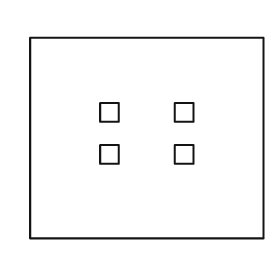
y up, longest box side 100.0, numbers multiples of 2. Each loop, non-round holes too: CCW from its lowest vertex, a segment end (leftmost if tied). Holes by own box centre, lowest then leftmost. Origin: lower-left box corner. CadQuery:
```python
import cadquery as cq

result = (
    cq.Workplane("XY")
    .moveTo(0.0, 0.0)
    .lineTo(100.0, 0.0)
    .lineTo(100.0, 86.0)
    .lineTo(0.0, 86.0)
    .close()
    .moveTo(30.0, 32.0)
    .lineTo(38.0, 32.0)
    .lineTo(38.0, 40.0)
    .lineTo(30.0, 40.0)
    .close()
    .moveTo(62.0, 32.0)
    .lineTo(70.0, 32.0)
    .lineTo(70.0, 40.0)
    .lineTo(62.0, 40.0)
    .close()
    .moveTo(30.0, 50.0)
    .lineTo(38.0, 50.0)
    .lineTo(38.0, 58.0)
    .lineTo(30.0, 58.0)
    .close()
    .moveTo(62.0, 50.0)
    .lineTo(70.0, 50.0)
    .lineTo(70.0, 58.0)
    .lineTo(62.0, 58.0)
    .close()
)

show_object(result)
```